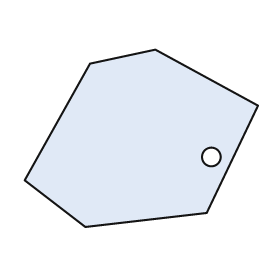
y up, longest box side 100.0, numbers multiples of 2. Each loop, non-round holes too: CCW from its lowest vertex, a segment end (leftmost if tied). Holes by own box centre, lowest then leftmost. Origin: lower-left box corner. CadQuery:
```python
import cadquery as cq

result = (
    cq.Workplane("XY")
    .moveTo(26.0, 0.0)
    .lineTo(78.0, 6.0)
    .lineTo(100.0, 52.0)
    .lineTo(56.0, 76.0)
    .lineTo(28.0, 70.0)
    .lineTo(0.0, 20.0)
    .close()
    .moveTo(80.0, 30.0)
    .circle(4.0)
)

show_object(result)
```